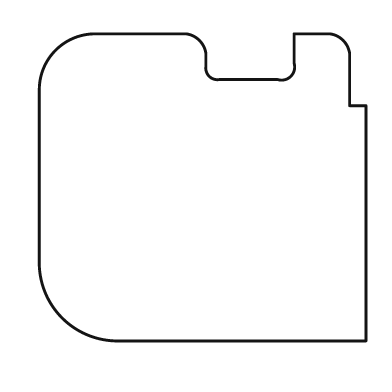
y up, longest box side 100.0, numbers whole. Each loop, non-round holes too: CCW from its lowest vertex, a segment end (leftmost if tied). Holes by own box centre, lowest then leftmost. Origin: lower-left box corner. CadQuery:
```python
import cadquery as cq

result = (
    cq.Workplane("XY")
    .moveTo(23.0, 0.0)
    .lineTo(100.0, 0.0)
    .lineTo(100.0, 72.0)
    .lineTo(95.0, 72.0)
    .lineTo(95.0, 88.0)
    .threePointArc((93.0, 92.0), (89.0, 94.0))
    .lineTo(78.0, 94.0)
    .lineTo(78.0, 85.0)
    .threePointArc((77.0, 81.0), (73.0, 80.0))
    .lineTo(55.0, 80.0)
    .threePointArc((52.0, 81.0), (51.0, 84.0))
    .lineTo(51.0, 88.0)
    .threePointArc((49.0, 92.0), (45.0, 94.0))
    .lineTo(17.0, 94.0)
    .threePointArc((5.0, 89.0), (0.0, 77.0))
    .lineTo(0.0, 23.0)
    .threePointArc((7.0, 7.0), (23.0, 0.0))
    .close()
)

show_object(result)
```